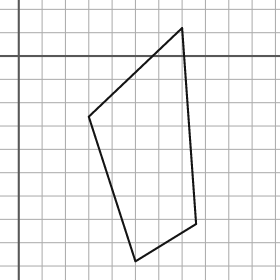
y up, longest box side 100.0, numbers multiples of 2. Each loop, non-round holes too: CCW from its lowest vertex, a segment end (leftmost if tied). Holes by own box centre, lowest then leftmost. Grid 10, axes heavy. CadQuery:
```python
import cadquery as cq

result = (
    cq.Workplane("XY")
    .moveTo(50.0, -88.0)
    .lineTo(76.0, -72.0)
    .lineTo(70.0, 12.0)
    .lineTo(30.0, -26.0)
    .close()
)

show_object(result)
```